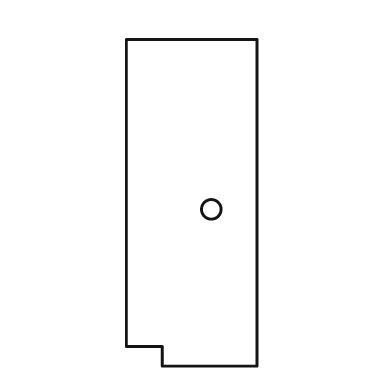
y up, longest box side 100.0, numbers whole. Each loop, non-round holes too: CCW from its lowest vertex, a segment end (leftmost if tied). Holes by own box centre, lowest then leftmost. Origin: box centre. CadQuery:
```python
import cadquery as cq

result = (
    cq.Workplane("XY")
    .moveTo(-9.0, -50.0)
    .lineTo(20.0, -50.0)
    .lineTo(20.0, 50.0)
    .lineTo(-20.0, 50.0)
    .lineTo(-20.0, -44.0)
    .lineTo(-9.0, -44.0)
    .close()
    .moveTo(6.0, -2.0)
    .circle(3.0)
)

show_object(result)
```